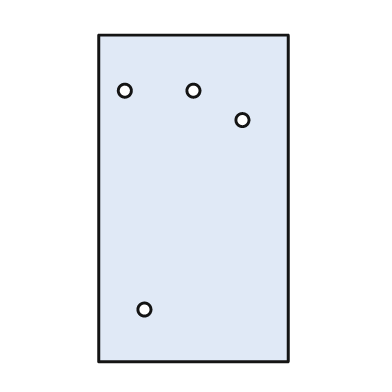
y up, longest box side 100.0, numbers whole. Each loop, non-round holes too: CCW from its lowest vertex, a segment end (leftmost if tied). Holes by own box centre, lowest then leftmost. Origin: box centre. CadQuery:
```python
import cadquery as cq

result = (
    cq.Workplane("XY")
    .moveTo(-29.0, -50.0)
    .lineTo(29.0, -50.0)
    .lineTo(29.0, 50.0)
    .lineTo(-29.0, 50.0)
    .close()
    .moveTo(-15.0, -34.0)
    .circle(2.0)
    .moveTo(15.0, 24.0)
    .circle(2.0)
    .moveTo(-21.0, 33.0)
    .circle(2.0)
    .moveTo(0.0, 33.0)
    .circle(2.0)
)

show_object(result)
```